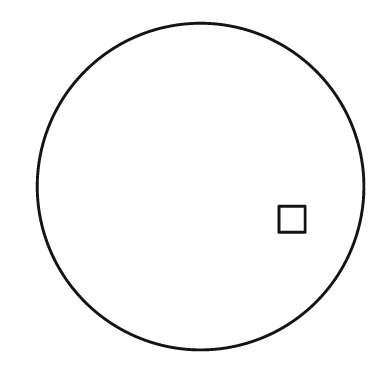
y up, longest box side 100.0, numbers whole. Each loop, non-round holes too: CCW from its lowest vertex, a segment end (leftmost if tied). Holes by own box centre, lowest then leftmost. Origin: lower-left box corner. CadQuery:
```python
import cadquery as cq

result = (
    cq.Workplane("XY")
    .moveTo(50.0, 50.0)
    .circle(50.0)
    .moveTo(74.0, 36.0)
    .lineTo(82.0, 36.0)
    .lineTo(82.0, 44.0)
    .lineTo(74.0, 44.0)
    .close()
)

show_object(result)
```